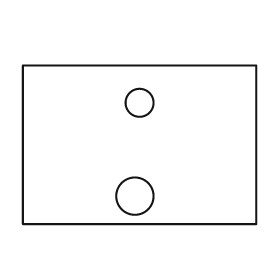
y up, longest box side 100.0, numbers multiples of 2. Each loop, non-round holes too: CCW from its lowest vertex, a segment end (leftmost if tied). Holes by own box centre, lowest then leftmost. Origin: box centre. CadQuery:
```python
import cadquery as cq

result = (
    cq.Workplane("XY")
    .moveTo(-50.0, -34.0)
    .lineTo(50.0, -34.0)
    .lineTo(50.0, 34.0)
    .lineTo(-50.0, 34.0)
    .close()
    .moveTo(-2.0, -22.0)
    .circle(8.0)
    .moveTo(0.0, 18.0)
    .circle(6.0)
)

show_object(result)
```